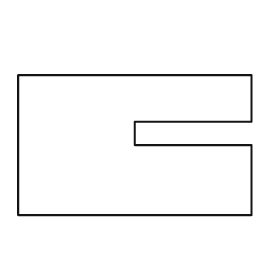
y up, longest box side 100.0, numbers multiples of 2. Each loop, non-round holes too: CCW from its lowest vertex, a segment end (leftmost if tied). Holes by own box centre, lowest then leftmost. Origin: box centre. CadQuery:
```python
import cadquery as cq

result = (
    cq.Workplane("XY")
    .moveTo(-50.0, -30.0)
    .lineTo(50.0, -30.0)
    .lineTo(50.0, 0.0)
    .lineTo(0.0, 0.0)
    .lineTo(0.0, 10.0)
    .lineTo(50.0, 10.0)
    .lineTo(50.0, 30.0)
    .lineTo(-50.0, 30.0)
    .close()
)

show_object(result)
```